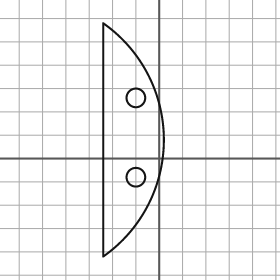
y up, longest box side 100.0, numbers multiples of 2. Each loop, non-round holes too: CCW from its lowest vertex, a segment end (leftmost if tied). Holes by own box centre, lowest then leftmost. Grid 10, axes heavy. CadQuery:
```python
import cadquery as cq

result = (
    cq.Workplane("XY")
    .moveTo(-24.0, -42.0)
    .threePointArc((2.0, 8.0), (-24.0, 58.0))
    .close()
    .moveTo(-10.0, -8.0)
    .circle(4.0)
    .moveTo(-10.0, 26.0)
    .circle(4.0)
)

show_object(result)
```